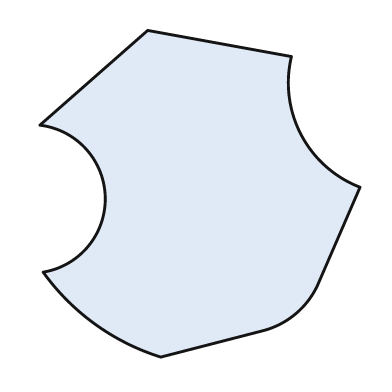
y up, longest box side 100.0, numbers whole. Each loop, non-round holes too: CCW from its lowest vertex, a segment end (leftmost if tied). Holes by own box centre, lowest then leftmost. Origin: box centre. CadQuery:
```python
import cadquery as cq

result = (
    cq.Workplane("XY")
    .moveTo(-12.0, -50.0)
    .lineTo(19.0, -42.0)
    .threePointArc((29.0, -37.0), (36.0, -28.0))
    .lineTo(49.0, 2.0)
    .threePointArc((31.0, 18.0), (28.0, 42.0))
    .lineTo(-16.0, 50.0)
    .lineTo(-49.0, 21.0)
    .threePointArc((-29.0, -1.0), (-48.0, -24.0))
    .threePointArc((-32.0, -40.0), (-12.0, -50.0))
    .close()
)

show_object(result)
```